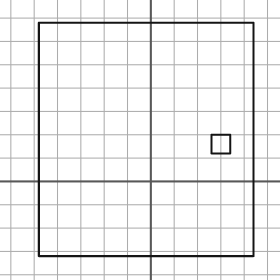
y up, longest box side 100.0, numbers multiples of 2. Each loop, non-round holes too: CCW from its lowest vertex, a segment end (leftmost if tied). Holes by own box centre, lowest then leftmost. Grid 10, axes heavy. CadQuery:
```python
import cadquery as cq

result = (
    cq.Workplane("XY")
    .moveTo(-48.0, -32.0)
    .lineTo(44.0, -32.0)
    .lineTo(44.0, 68.0)
    .lineTo(-48.0, 68.0)
    .close()
    .moveTo(26.0, 12.0)
    .lineTo(34.0, 12.0)
    .lineTo(34.0, 20.0)
    .lineTo(26.0, 20.0)
    .close()
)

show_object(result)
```